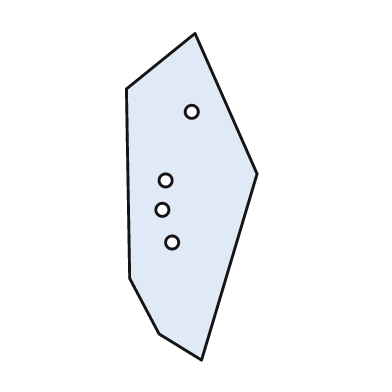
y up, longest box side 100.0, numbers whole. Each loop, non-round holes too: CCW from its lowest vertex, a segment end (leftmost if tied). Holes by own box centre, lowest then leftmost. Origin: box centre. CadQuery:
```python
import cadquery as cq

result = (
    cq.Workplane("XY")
    .moveTo(3.0, -50.0)
    .lineTo(20.0, 7.0)
    .lineTo(1.0, 50.0)
    .lineTo(-20.0, 33.0)
    .lineTo(-19.0, -25.0)
    .lineTo(-10.0, -42.0)
    .close()
    .moveTo(-6.0, -14.0)
    .circle(2.0)
    .moveTo(-9.0, -4.0)
    .circle(2.0)
    .moveTo(-8.0, 5.0)
    .circle(2.0)
    .moveTo(0.0, 26.0)
    .circle(2.0)
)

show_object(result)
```